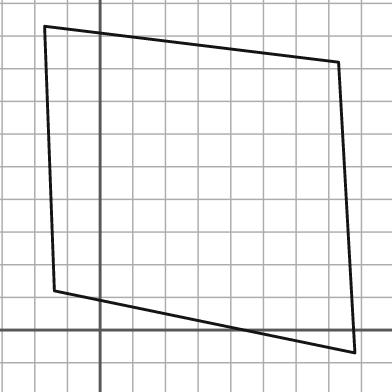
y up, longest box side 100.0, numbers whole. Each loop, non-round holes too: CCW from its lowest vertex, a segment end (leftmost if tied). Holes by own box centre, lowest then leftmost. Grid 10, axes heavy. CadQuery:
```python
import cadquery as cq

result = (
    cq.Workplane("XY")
    .moveTo(78.0, -7.0)
    .lineTo(73.0, 82.0)
    .lineTo(-17.0, 93.0)
    .lineTo(-14.0, 12.0)
    .close()
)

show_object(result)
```